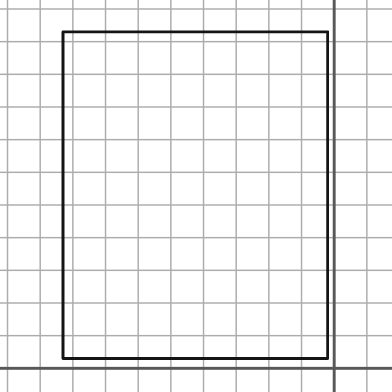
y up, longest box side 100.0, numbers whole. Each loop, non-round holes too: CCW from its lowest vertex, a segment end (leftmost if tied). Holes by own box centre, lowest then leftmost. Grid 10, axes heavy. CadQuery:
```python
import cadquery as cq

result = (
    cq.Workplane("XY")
    .moveTo(-83.0, 3.0)
    .lineTo(-2.0, 3.0)
    .lineTo(-2.0, 103.0)
    .lineTo(-83.0, 103.0)
    .close()
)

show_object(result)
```